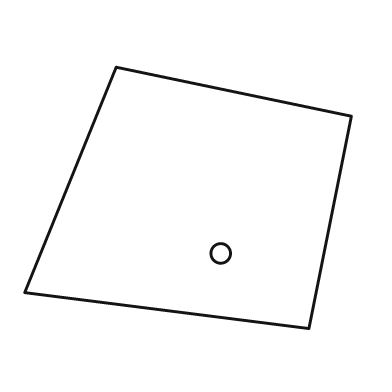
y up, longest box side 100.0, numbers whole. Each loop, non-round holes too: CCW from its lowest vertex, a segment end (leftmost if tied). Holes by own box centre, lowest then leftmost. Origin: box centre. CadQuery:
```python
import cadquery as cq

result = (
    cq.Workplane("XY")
    .moveTo(37.0, -40.0)
    .lineTo(50.0, 25.0)
    .lineTo(-22.0, 40.0)
    .lineTo(-50.0, -29.0)
    .close()
    .moveTo(10.0, -17.0)
    .circle(3.0)
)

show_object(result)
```